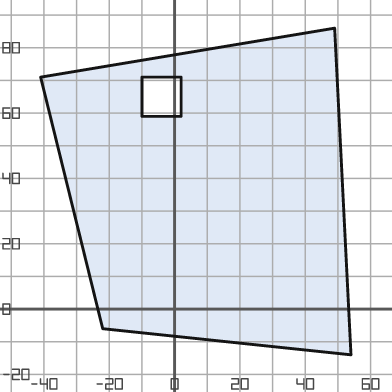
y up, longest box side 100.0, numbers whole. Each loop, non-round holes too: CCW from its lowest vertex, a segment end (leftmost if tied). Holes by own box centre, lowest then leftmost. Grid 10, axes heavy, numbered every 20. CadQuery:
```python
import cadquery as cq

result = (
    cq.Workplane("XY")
    .moveTo(54.0, -14.0)
    .lineTo(49.0, 86.0)
    .lineTo(-41.0, 71.0)
    .lineTo(-22.0, -6.0)
    .close()
    .moveTo(-10.0, 59.0)
    .lineTo(2.0, 59.0)
    .lineTo(2.0, 71.0)
    .lineTo(-10.0, 71.0)
    .close()
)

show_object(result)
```